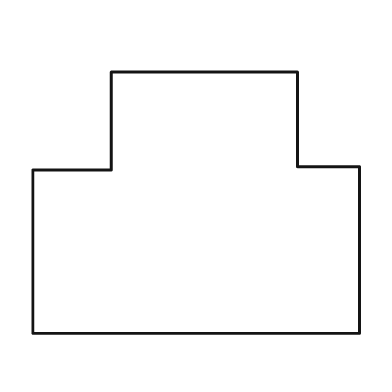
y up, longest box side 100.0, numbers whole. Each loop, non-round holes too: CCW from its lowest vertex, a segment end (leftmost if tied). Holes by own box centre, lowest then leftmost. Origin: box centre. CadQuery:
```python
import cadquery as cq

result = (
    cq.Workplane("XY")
    .moveTo(-50.0, -40.0)
    .lineTo(50.0, -40.0)
    .lineTo(50.0, 11.0)
    .lineTo(31.0, 11.0)
    .lineTo(31.0, 40.0)
    .lineTo(-26.0, 40.0)
    .lineTo(-26.0, 10.0)
    .lineTo(-50.0, 10.0)
    .close()
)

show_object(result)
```